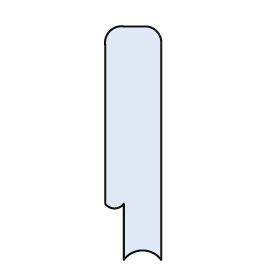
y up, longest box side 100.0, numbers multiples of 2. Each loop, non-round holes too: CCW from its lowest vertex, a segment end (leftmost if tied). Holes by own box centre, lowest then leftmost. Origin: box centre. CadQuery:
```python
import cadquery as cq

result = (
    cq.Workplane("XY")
    .moveTo(-4.0, -50.0)
    .threePointArc((4.0, -46.0), (12.0, -50.0))
    .lineTo(12.0, 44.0)
    .threePointArc((10.0, 48.0), (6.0, 50.0))
    .lineTo(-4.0, 50.0)
    .threePointArc((-10.0, 48.0), (-12.0, 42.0))
    .lineTo(-12.0, -26.0)
    .threePointArc((-8.0, -28.0), (-4.0, -26.0))
    .close()
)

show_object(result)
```